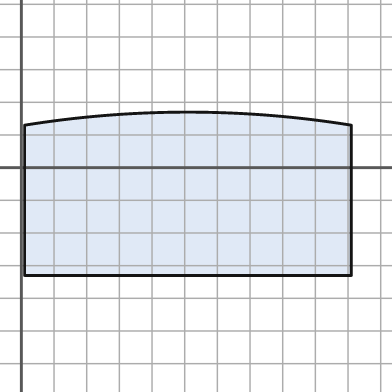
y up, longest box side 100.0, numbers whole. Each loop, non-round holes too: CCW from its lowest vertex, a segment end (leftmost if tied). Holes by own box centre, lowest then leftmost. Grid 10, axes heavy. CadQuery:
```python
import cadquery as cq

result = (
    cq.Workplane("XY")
    .moveTo(1.0, -33.0)
    .lineTo(101.0, -33.0)
    .lineTo(101.0, 13.0)
    .threePointArc((51.0, 17.0), (1.0, 13.0))
    .close()
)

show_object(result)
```